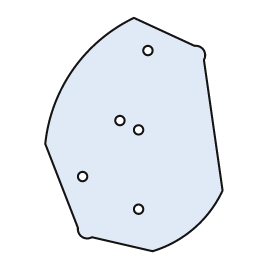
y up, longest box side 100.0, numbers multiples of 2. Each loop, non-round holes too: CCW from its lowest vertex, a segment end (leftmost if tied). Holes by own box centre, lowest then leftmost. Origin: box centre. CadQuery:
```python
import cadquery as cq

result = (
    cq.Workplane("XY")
    .moveTo(8.0, -50.0)
    .threePointArc((26.0, -40.0), (38.0, -24.0))
    .lineTo(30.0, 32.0)
    .threePointArc((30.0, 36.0), (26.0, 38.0))
    .lineTo(0.0, 50.0)
    .threePointArc((-26.0, 28.0), (-38.0, -4.0))
    .lineTo(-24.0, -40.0)
    .threePointArc((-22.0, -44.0), (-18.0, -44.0))
    .close()
    .moveTo(2.0, -32.0)
    .circle(2.0)
    .moveTo(-22.0, -18.0)
    .circle(2.0)
    .moveTo(2.0, 2.0)
    .circle(2.0)
    .moveTo(-6.0, 6.0)
    .circle(2.0)
    .moveTo(6.0, 36.0)
    .circle(2.0)
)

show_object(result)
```